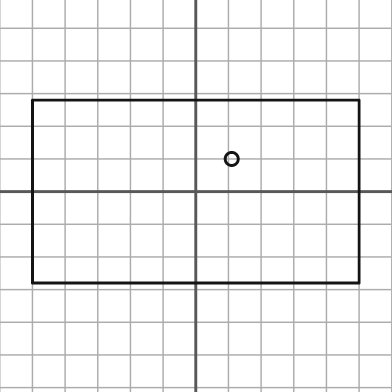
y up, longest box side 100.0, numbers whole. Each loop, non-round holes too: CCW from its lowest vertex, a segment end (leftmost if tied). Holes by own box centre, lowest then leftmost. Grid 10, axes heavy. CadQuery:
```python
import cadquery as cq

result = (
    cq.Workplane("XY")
    .moveTo(-50.0, -28.0)
    .lineTo(50.0, -28.0)
    .lineTo(50.0, 28.0)
    .lineTo(-50.0, 28.0)
    .close()
    .moveTo(11.0, 10.0)
    .circle(2.0)
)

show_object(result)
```